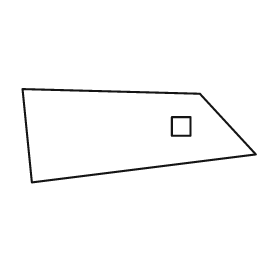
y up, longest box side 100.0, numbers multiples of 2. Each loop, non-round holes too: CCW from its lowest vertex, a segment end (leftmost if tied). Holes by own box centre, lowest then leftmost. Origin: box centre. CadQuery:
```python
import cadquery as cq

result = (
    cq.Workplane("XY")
    .moveTo(-46.0, -20.0)
    .lineTo(50.0, -8.0)
    .lineTo(26.0, 18.0)
    .lineTo(-50.0, 20.0)
    .close()
    .moveTo(14.0, 0.0)
    .lineTo(22.0, 0.0)
    .lineTo(22.0, 8.0)
    .lineTo(14.0, 8.0)
    .close()
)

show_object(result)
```